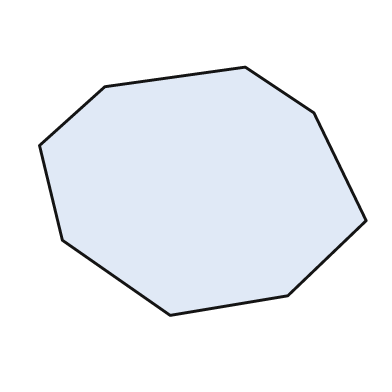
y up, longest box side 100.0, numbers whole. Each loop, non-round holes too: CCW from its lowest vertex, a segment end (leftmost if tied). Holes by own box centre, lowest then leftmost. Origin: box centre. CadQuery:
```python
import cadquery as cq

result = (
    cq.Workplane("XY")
    .moveTo(-10.0, -38.0)
    .lineTo(26.0, -32.0)
    .lineTo(50.0, -9.0)
    .lineTo(34.0, 24.0)
    .lineTo(13.0, 38.0)
    .lineTo(-30.0, 32.0)
    .lineTo(-50.0, 14.0)
    .lineTo(-43.0, -15.0)
    .close()
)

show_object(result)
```